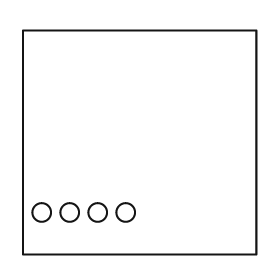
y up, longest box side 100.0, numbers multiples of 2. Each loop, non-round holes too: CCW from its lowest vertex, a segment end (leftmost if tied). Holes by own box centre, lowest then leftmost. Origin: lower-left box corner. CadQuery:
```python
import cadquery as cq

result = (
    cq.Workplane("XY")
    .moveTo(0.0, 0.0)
    .lineTo(100.0, 0.0)
    .lineTo(100.0, 96.0)
    .lineTo(0.0, 96.0)
    .close()
    .moveTo(8.0, 18.0)
    .circle(4.0)
    .moveTo(20.0, 18.0)
    .circle(4.0)
    .moveTo(32.0, 18.0)
    .circle(4.0)
    .moveTo(44.0, 18.0)
    .circle(4.0)
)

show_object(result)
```